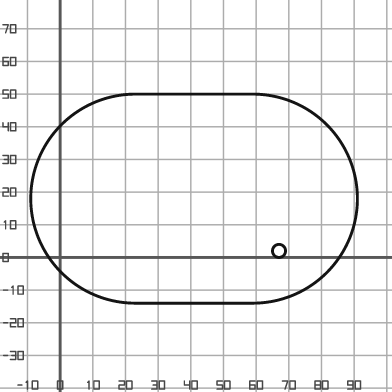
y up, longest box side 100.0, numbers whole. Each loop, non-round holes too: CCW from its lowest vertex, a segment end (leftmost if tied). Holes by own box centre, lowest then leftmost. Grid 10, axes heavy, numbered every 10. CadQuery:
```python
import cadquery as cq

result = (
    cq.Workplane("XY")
    .moveTo(23.0, -14.0)
    .lineTo(59.0, -14.0)
    .threePointArc((91.0, 18.0), (59.0, 50.0))
    .lineTo(23.0, 50.0)
    .threePointArc((-9.0, 18.0), (23.0, -14.0))
    .close()
    .moveTo(67.0, 2.0)
    .circle(2.0)
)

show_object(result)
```